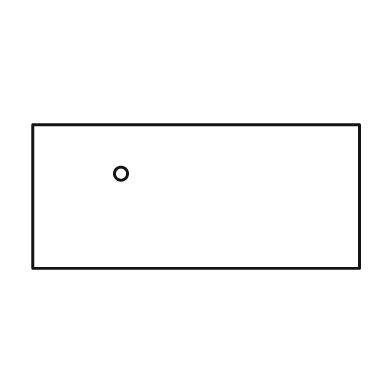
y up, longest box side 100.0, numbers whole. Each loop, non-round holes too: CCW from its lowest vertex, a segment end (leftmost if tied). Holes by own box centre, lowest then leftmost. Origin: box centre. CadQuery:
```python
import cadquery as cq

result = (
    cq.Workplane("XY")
    .moveTo(-50.0, -22.0)
    .lineTo(50.0, -22.0)
    .lineTo(50.0, 22.0)
    .lineTo(-50.0, 22.0)
    .close()
    .moveTo(-23.0, 7.0)
    .circle(2.0)
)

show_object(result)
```